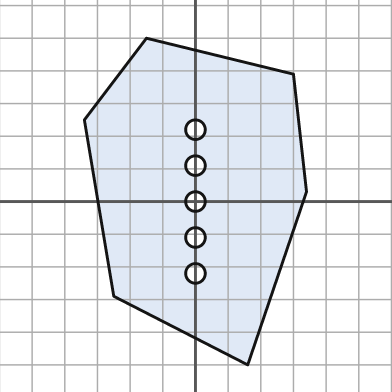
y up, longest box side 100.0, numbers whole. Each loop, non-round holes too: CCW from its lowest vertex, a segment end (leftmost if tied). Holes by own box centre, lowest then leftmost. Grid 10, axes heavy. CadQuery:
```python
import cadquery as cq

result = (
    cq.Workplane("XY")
    .moveTo(16.0, -50.0)
    .lineTo(34.0, 3.0)
    .lineTo(30.0, 39.0)
    .lineTo(-15.0, 50.0)
    .lineTo(-34.0, 25.0)
    .lineTo(-25.0, -29.0)
    .close()
    .moveTo(0.0, -22.0)
    .circle(3.0)
    .moveTo(0.0, -11.0)
    .circle(3.0)
    .moveTo(0.0, 0.0)
    .circle(3.0)
    .moveTo(0.0, 11.0)
    .circle(3.0)
    .moveTo(0.0, 22.0)
    .circle(3.0)
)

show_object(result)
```